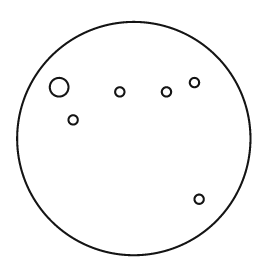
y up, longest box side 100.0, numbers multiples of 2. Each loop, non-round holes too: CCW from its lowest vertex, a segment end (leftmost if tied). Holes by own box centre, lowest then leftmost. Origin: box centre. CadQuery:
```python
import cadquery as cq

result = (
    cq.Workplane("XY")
    .moveTo(0.0, 0.0)
    .circle(50.0)
    .moveTo(28.0, -26.0)
    .circle(2.0)
    .moveTo(-26.0, 8.0)
    .circle(2.0)
    .moveTo(-6.0, 20.0)
    .circle(2.0)
    .moveTo(14.0, 20.0)
    .circle(2.0)
    .moveTo(-32.0, 22.0)
    .circle(4.0)
    .moveTo(26.0, 24.0)
    .circle(2.0)
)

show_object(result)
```